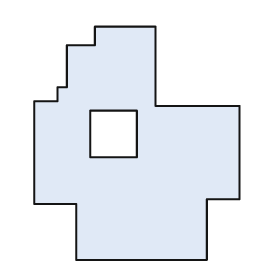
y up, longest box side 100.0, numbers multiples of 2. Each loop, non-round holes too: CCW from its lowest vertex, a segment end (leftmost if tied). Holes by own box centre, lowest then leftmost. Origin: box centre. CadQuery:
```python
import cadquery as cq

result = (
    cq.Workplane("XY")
    .moveTo(-26.0, -50.0)
    .lineTo(30.0, -50.0)
    .lineTo(30.0, -24.0)
    .lineTo(44.0, -24.0)
    .lineTo(44.0, 16.0)
    .lineTo(8.0, 16.0)
    .lineTo(8.0, 50.0)
    .lineTo(-18.0, 50.0)
    .lineTo(-18.0, 42.0)
    .lineTo(-30.0, 42.0)
    .lineTo(-30.0, 24.0)
    .lineTo(-34.0, 24.0)
    .lineTo(-34.0, 18.0)
    .lineTo(-44.0, 18.0)
    .lineTo(-44.0, -26.0)
    .lineTo(-26.0, -26.0)
    .close()
    .moveTo(-20.0, -6.0)
    .lineTo(0.0, -6.0)
    .lineTo(0.0, 14.0)
    .lineTo(-20.0, 14.0)
    .close()
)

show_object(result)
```